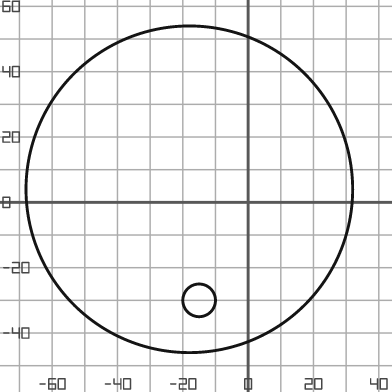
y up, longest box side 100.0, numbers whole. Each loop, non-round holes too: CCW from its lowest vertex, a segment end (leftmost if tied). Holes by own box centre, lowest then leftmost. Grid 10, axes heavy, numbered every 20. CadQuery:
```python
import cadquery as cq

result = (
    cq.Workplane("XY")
    .moveTo(-18.0, 4.0)
    .circle(50.0)
    .moveTo(-15.0, -30.0)
    .circle(5.0)
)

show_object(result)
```